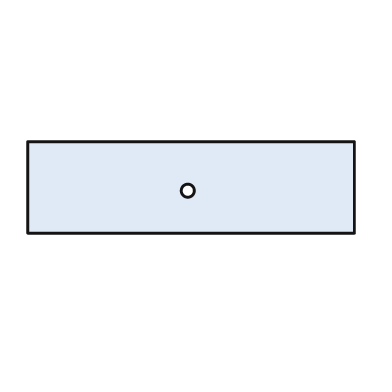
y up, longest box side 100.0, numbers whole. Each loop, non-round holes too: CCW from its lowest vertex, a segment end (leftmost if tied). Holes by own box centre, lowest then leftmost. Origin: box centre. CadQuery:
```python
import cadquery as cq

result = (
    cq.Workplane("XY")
    .moveTo(-50.0, -14.0)
    .lineTo(50.0, -14.0)
    .lineTo(50.0, 14.0)
    .lineTo(-50.0, 14.0)
    .close()
    .moveTo(-1.0, -1.0)
    .circle(2.0)
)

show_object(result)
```